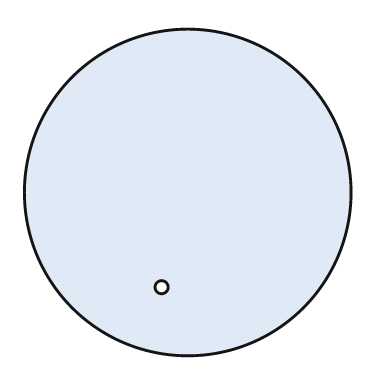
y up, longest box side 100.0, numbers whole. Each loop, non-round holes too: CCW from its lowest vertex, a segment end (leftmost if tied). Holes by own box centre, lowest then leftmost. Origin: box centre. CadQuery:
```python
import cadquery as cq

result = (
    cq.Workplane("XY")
    .moveTo(0.0, 0.0)
    .circle(50.0)
    .moveTo(-8.0, -29.0)
    .circle(2.0)
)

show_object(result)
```